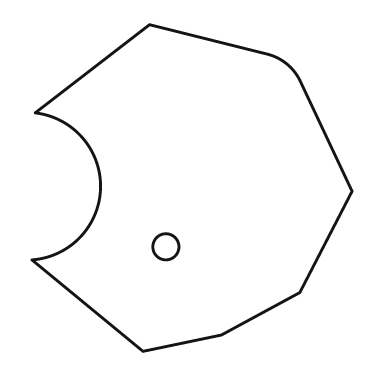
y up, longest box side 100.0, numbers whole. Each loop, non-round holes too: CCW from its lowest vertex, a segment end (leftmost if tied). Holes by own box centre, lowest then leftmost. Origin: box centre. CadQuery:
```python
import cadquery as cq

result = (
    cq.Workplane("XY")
    .moveTo(-15.0, -50.0)
    .lineTo(9.0, -45.0)
    .lineTo(33.0, -32.0)
    .lineTo(49.0, -1.0)
    .lineTo(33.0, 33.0)
    .threePointArc((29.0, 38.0), (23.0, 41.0))
    .lineTo(-13.0, 50.0)
    .lineTo(-48.0, 23.0)
    .threePointArc((-28.0, 0.0), (-49.0, -22.0))
    .close()
    .moveTo(-8.0, -18.0)
    .circle(4.0)
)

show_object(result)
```